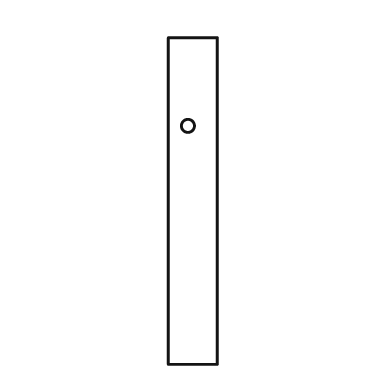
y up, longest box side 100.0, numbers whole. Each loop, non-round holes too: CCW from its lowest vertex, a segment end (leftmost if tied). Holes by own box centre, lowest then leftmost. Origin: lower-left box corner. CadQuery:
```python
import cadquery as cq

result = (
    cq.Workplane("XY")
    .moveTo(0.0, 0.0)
    .lineTo(15.0, 0.0)
    .lineTo(15.0, 100.0)
    .lineTo(0.0, 100.0)
    .close()
    .moveTo(6.0, 73.0)
    .circle(2.0)
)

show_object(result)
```